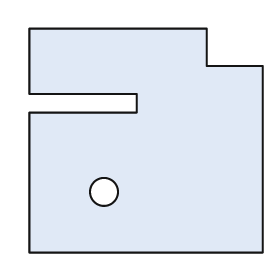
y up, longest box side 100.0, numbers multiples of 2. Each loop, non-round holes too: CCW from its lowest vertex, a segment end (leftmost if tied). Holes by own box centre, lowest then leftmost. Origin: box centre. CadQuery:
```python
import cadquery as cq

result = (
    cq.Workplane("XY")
    .moveTo(-50.0, -48.0)
    .lineTo(50.0, -48.0)
    .lineTo(50.0, 32.0)
    .lineTo(26.0, 32.0)
    .lineTo(26.0, 48.0)
    .lineTo(-50.0, 48.0)
    .lineTo(-50.0, 20.0)
    .lineTo(-4.0, 20.0)
    .lineTo(-4.0, 12.0)
    .lineTo(-50.0, 12.0)
    .close()
    .moveTo(-18.0, -22.0)
    .circle(6.0)
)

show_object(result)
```